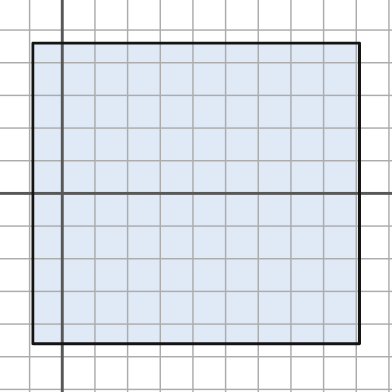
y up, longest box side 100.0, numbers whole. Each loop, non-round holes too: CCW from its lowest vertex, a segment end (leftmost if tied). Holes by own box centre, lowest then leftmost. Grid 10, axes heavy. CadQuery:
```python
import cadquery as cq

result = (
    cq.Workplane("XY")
    .moveTo(-9.0, -46.0)
    .lineTo(91.0, -46.0)
    .lineTo(91.0, 46.0)
    .lineTo(-9.0, 46.0)
    .close()
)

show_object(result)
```